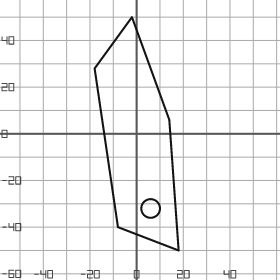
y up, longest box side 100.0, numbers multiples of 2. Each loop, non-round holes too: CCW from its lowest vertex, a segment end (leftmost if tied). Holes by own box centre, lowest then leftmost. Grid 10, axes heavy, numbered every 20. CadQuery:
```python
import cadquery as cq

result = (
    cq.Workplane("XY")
    .moveTo(18.0, -50.0)
    .lineTo(14.0, 6.0)
    .lineTo(-2.0, 50.0)
    .lineTo(-18.0, 28.0)
    .lineTo(-8.0, -40.0)
    .close()
    .moveTo(6.0, -32.0)
    .circle(4.0)
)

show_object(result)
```